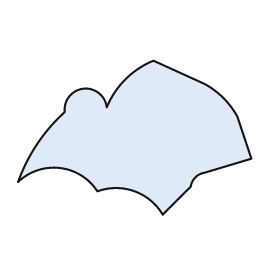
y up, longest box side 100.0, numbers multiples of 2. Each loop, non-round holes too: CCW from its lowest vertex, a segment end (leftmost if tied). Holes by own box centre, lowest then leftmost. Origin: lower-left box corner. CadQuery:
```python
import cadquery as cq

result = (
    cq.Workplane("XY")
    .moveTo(62.0, 0.0)
    .lineTo(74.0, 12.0)
    .threePointArc((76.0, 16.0), (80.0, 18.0))
    .lineTo(100.0, 24.0)
    .lineTo(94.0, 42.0)
    .threePointArc((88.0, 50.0), (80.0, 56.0))
    .lineTo(58.0, 66.0)
    .threePointArc((46.0, 58.0), (38.0, 46.0))
    .threePointArc((28.0, 54.0), (20.0, 44.0))
    .threePointArc((8.0, 30.0), (0.0, 14.0))
    .threePointArc((18.0, 20.0), (34.0, 10.0))
    .threePointArc((50.0, 10.0), (62.0, 0.0))
    .close()
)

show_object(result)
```